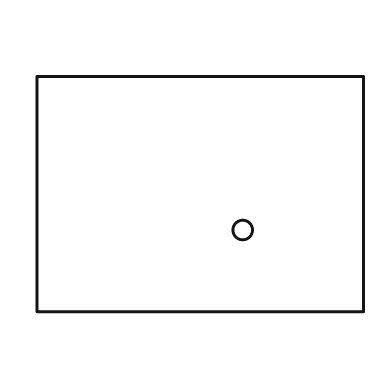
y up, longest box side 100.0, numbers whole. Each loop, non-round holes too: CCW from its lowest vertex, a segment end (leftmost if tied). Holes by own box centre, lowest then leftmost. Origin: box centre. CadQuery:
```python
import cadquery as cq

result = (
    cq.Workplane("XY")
    .moveTo(-50.0, -36.0)
    .lineTo(50.0, -36.0)
    .lineTo(50.0, 36.0)
    .lineTo(-50.0, 36.0)
    .close()
    .moveTo(13.0, -11.0)
    .circle(3.0)
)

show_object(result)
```